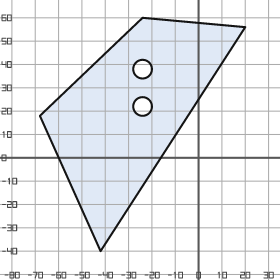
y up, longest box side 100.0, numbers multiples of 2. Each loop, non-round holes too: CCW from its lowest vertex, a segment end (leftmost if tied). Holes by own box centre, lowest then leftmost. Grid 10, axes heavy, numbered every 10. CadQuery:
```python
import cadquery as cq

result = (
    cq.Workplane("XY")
    .moveTo(-42.0, -40.0)
    .lineTo(20.0, 56.0)
    .lineTo(-24.0, 60.0)
    .lineTo(-68.0, 18.0)
    .close()
    .moveTo(-24.0, 22.0)
    .circle(4.0)
    .moveTo(-24.0, 38.0)
    .circle(4.0)
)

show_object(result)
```